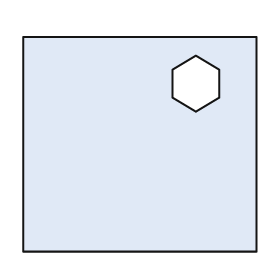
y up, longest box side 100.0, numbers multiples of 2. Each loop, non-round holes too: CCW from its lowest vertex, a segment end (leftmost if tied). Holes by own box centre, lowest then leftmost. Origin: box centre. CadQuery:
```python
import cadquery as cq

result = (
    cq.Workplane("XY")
    .moveTo(-50.0, -46.0)
    .lineTo(50.0, -46.0)
    .lineTo(50.0, 46.0)
    .lineTo(-50.0, 46.0)
    .close()
    .moveTo(24.0, 14.0)
    .lineTo(34.0, 20.0)
    .lineTo(34.0, 32.0)
    .lineTo(24.0, 38.0)
    .lineTo(14.0, 32.0)
    .lineTo(14.0, 20.0)
    .close()
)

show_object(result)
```